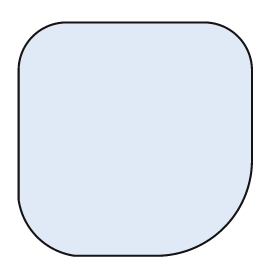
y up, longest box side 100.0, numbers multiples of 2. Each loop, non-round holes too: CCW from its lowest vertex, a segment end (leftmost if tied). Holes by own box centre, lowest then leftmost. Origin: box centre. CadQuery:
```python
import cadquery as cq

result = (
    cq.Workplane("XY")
    .moveTo(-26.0, -50.0)
    .lineTo(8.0, -50.0)
    .threePointArc((38.0, -38.0), (50.0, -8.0))
    .lineTo(50.0, 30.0)
    .threePointArc((44.0, 44.0), (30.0, 50.0))
    .lineTo(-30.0, 50.0)
    .threePointArc((-44.0, 44.0), (-50.0, 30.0))
    .lineTo(-50.0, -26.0)
    .threePointArc((-42.0, -42.0), (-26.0, -50.0))
    .close()
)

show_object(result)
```